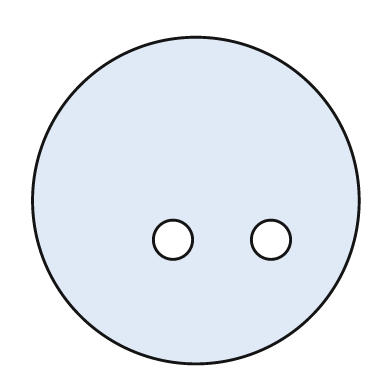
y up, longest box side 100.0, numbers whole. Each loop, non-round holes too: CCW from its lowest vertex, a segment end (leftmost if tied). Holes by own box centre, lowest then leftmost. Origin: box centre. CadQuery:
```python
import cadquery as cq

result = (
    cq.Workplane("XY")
    .moveTo(0.0, 0.0)
    .circle(50.0)
    .moveTo(-7.0, -12.0)
    .circle(6.0)
    .moveTo(23.0, -12.0)
    .circle(6.0)
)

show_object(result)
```